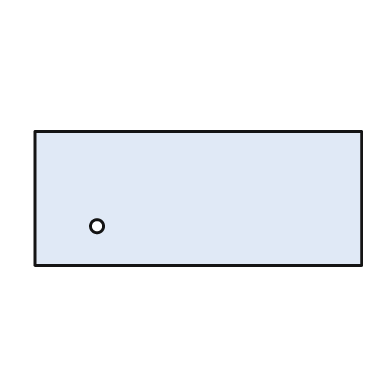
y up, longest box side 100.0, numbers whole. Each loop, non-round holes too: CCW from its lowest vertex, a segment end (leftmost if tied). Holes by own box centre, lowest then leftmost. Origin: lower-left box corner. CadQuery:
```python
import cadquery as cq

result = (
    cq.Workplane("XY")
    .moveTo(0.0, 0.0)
    .lineTo(100.0, 0.0)
    .lineTo(100.0, 41.0)
    .lineTo(0.0, 41.0)
    .close()
    .moveTo(19.0, 12.0)
    .circle(2.0)
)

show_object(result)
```